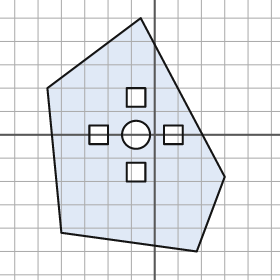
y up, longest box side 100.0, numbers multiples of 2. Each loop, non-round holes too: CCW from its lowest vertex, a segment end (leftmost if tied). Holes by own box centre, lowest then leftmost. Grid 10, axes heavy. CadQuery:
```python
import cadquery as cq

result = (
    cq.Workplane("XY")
    .moveTo(18.0, -50.0)
    .lineTo(30.0, -18.0)
    .lineTo(-6.0, 50.0)
    .lineTo(-46.0, 20.0)
    .lineTo(-40.0, -42.0)
    .close()
    .moveTo(-12.0, -20.0)
    .lineTo(-4.0, -20.0)
    .lineTo(-4.0, -12.0)
    .lineTo(-12.0, -12.0)
    .close()
    .moveTo(-28.0, -4.0)
    .lineTo(-20.0, -4.0)
    .lineTo(-20.0, 4.0)
    .lineTo(-28.0, 4.0)
    .close()
    .moveTo(-8.0, 0.0)
    .circle(6.0)
    .moveTo(4.0, -4.0)
    .lineTo(12.0, -4.0)
    .lineTo(12.0, 4.0)
    .lineTo(4.0, 4.0)
    .close()
    .moveTo(-12.0, 12.0)
    .lineTo(-4.0, 12.0)
    .lineTo(-4.0, 20.0)
    .lineTo(-12.0, 20.0)
    .close()
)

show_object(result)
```